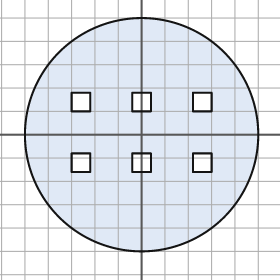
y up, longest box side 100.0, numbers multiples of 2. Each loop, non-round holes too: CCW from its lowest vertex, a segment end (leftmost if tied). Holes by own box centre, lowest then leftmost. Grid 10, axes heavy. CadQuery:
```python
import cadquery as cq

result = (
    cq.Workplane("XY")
    .moveTo(0.0, 0.0)
    .circle(50.0)
    .moveTo(-30.0, -16.0)
    .lineTo(-22.0, -16.0)
    .lineTo(-22.0, -8.0)
    .lineTo(-30.0, -8.0)
    .close()
    .moveTo(-4.0, -16.0)
    .lineTo(4.0, -16.0)
    .lineTo(4.0, -8.0)
    .lineTo(-4.0, -8.0)
    .close()
    .moveTo(22.0, -16.0)
    .lineTo(30.0, -16.0)
    .lineTo(30.0, -8.0)
    .lineTo(22.0, -8.0)
    .close()
    .moveTo(-30.0, 10.0)
    .lineTo(-22.0, 10.0)
    .lineTo(-22.0, 18.0)
    .lineTo(-30.0, 18.0)
    .close()
    .moveTo(-4.0, 10.0)
    .lineTo(4.0, 10.0)
    .lineTo(4.0, 18.0)
    .lineTo(-4.0, 18.0)
    .close()
    .moveTo(22.0, 10.0)
    .lineTo(30.0, 10.0)
    .lineTo(30.0, 18.0)
    .lineTo(22.0, 18.0)
    .close()
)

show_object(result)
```